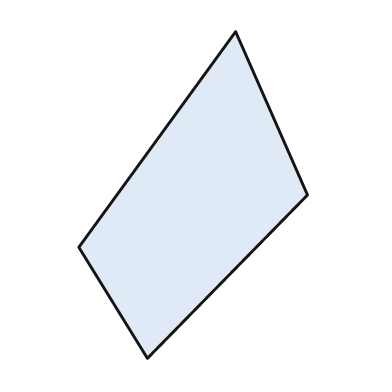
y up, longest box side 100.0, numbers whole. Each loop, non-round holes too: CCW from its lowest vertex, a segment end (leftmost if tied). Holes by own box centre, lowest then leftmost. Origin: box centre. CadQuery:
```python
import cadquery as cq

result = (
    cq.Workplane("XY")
    .moveTo(-14.0, -50.0)
    .lineTo(35.0, 0.0)
    .lineTo(13.0, 50.0)
    .lineTo(-35.0, -16.0)
    .close()
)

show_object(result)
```